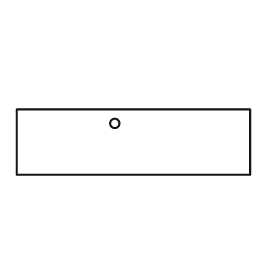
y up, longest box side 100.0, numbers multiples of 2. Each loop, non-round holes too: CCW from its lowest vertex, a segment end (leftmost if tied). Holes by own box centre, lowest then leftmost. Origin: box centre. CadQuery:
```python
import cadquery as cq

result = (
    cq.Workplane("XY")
    .moveTo(-50.0, -14.0)
    .lineTo(50.0, -14.0)
    .lineTo(50.0, 14.0)
    .lineTo(-50.0, 14.0)
    .close()
    .moveTo(-8.0, 8.0)
    .circle(2.0)
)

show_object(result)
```